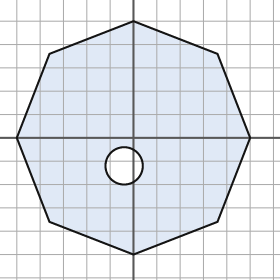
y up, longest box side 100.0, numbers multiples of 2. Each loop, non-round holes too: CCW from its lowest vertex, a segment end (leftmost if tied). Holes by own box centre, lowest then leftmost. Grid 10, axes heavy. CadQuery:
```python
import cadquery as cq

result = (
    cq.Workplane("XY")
    .moveTo(0.0, -50.0)
    .lineTo(36.0, -36.0)
    .lineTo(50.0, 0.0)
    .lineTo(36.0, 36.0)
    .lineTo(0.0, 50.0)
    .lineTo(-36.0, 36.0)
    .lineTo(-50.0, 0.0)
    .lineTo(-36.0, -36.0)
    .close()
    .moveTo(-4.0, -12.0)
    .circle(8.0)
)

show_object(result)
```